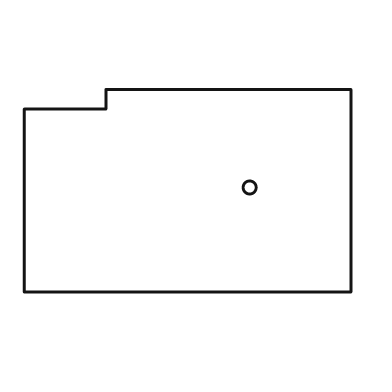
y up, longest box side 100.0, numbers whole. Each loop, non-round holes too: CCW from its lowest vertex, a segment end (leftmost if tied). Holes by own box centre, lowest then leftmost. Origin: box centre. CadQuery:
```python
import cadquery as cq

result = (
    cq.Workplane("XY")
    .moveTo(-50.0, -31.0)
    .lineTo(50.0, -31.0)
    .lineTo(50.0, 31.0)
    .lineTo(-25.0, 31.0)
    .lineTo(-25.0, 25.0)
    .lineTo(-50.0, 25.0)
    .close()
    .moveTo(19.0, 1.0)
    .circle(2.0)
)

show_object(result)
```